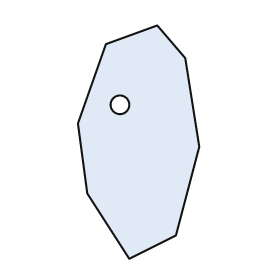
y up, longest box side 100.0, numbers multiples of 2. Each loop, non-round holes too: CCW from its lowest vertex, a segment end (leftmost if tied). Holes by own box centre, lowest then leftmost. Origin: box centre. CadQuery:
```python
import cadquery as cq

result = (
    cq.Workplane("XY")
    .moveTo(-4.0, -50.0)
    .lineTo(16.0, -40.0)
    .lineTo(26.0, -2.0)
    .lineTo(20.0, 36.0)
    .lineTo(8.0, 50.0)
    .lineTo(-14.0, 42.0)
    .lineTo(-26.0, 8.0)
    .lineTo(-22.0, -22.0)
    .close()
    .moveTo(-8.0, 16.0)
    .circle(4.0)
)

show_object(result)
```